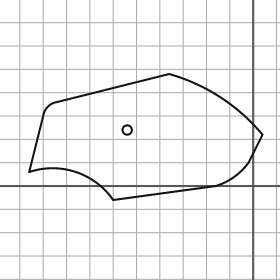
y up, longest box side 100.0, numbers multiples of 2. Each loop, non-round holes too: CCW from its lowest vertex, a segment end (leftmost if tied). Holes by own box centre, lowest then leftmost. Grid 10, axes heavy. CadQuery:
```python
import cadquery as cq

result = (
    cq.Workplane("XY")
    .moveTo(-60.0, -6.0)
    .lineTo(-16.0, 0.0)
    .threePointArc((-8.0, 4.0), (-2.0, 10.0))
    .lineTo(4.0, 22.0)
    .threePointArc((-14.0, 38.0), (-36.0, 48.0))
    .lineTo(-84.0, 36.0)
    .threePointArc((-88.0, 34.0), (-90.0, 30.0))
    .lineTo(-96.0, 6.0)
    .threePointArc((-76.0, 6.0), (-60.0, -6.0))
    .close()
    .moveTo(-54.0, 24.0)
    .circle(2.0)
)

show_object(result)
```